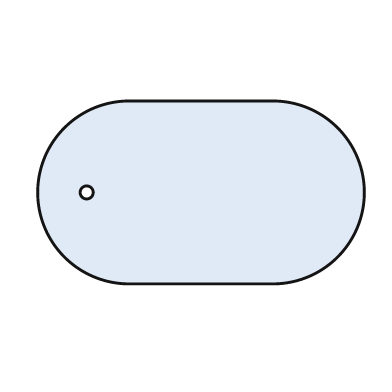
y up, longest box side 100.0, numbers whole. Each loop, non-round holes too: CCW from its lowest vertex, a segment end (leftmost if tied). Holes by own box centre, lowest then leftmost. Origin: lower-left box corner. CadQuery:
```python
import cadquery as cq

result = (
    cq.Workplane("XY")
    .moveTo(28.0, 0.0)
    .lineTo(72.0, 0.0)
    .threePointArc((100.0, 28.0), (72.0, 56.0))
    .lineTo(28.0, 56.0)
    .threePointArc((0.0, 28.0), (28.0, 0.0))
    .close()
    .moveTo(15.0, 28.0)
    .circle(2.0)
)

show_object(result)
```